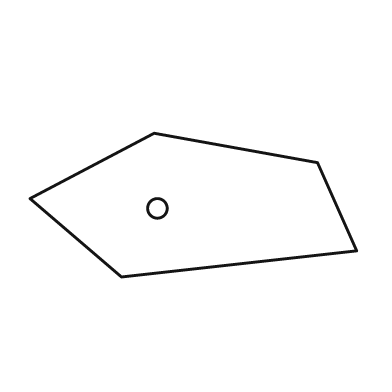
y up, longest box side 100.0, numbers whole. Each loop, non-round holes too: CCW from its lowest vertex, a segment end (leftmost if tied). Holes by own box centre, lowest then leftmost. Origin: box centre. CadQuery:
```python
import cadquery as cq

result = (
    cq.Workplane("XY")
    .moveTo(-22.0, -22.0)
    .lineTo(50.0, -14.0)
    .lineTo(38.0, 13.0)
    .lineTo(-12.0, 22.0)
    .lineTo(-50.0, 2.0)
    .close()
    .moveTo(-11.0, -1.0)
    .circle(3.0)
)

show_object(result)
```